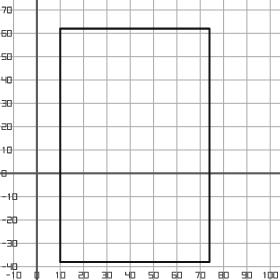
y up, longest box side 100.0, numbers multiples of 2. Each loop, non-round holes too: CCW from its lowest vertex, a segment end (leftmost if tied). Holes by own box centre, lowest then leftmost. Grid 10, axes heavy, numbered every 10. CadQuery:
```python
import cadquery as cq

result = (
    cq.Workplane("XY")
    .moveTo(10.0, -38.0)
    .lineTo(74.0, -38.0)
    .lineTo(74.0, 62.0)
    .lineTo(10.0, 62.0)
    .close()
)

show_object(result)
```